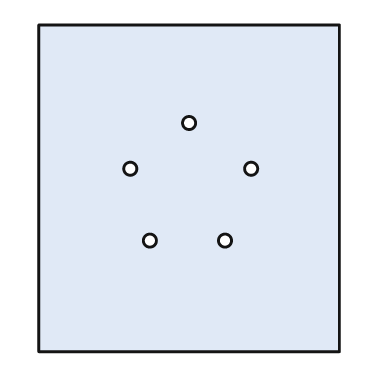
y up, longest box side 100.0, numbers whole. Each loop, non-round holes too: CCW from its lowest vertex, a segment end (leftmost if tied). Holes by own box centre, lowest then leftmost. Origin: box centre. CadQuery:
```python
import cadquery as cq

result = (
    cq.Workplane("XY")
    .moveTo(-46.0, -50.0)
    .lineTo(46.0, -50.0)
    .lineTo(46.0, 50.0)
    .lineTo(-46.0, 50.0)
    .close()
    .moveTo(-12.0, -16.0)
    .circle(2.0)
    .moveTo(11.0, -16.0)
    .circle(2.0)
    .moveTo(-18.0, 6.0)
    .circle(2.0)
    .moveTo(19.0, 6.0)
    .circle(2.0)
    .moveTo(0.0, 20.0)
    .circle(2.0)
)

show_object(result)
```